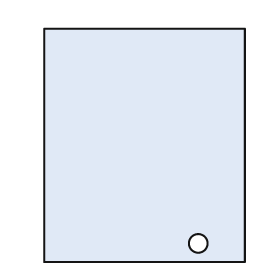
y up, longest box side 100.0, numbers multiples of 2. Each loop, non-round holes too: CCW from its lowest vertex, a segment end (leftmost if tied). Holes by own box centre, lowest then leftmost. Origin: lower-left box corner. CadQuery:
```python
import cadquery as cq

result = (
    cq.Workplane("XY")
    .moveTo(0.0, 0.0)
    .lineTo(86.0, 0.0)
    .lineTo(86.0, 100.0)
    .lineTo(0.0, 100.0)
    .close()
    .moveTo(66.0, 8.0)
    .circle(4.0)
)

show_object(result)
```